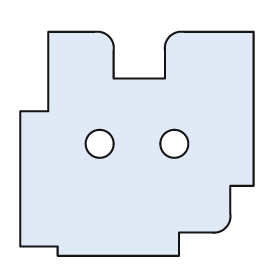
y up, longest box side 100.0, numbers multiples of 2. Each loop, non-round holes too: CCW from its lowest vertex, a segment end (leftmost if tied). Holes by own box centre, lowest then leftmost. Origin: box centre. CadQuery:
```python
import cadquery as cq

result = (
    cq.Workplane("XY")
    .moveTo(-34.0, -48.0)
    .lineTo(18.0, -48.0)
    .lineTo(18.0, -38.0)
    .lineTo(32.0, -38.0)
    .threePointArc((38.0, -36.0), (40.0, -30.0))
    .lineTo(40.0, -18.0)
    .lineTo(50.0, -18.0)
    .lineTo(50.0, 48.0)
    .lineTo(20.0, 48.0)
    .threePointArc((14.0, 46.0), (12.0, 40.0))
    .lineTo(12.0, 28.0)
    .lineTo(-10.0, 28.0)
    .lineTo(-10.0, 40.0)
    .threePointArc((-12.0, 46.0), (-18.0, 48.0))
    .lineTo(-38.0, 48.0)
    .lineTo(-38.0, 14.0)
    .lineTo(-50.0, 14.0)
    .lineTo(-50.0, -44.0)
    .lineTo(-34.0, -44.0)
    .close()
    .moveTo(-16.0, 0.0)
    .circle(6.0)
    .moveTo(16.0, 0.0)
    .circle(6.0)
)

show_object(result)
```